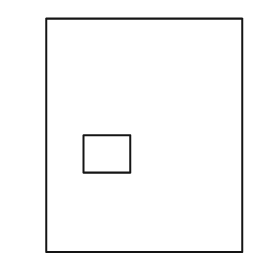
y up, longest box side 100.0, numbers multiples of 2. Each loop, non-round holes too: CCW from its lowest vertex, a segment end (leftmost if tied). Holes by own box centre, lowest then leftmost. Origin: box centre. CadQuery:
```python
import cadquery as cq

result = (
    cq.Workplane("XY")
    .moveTo(-42.0, -50.0)
    .lineTo(42.0, -50.0)
    .lineTo(42.0, 50.0)
    .lineTo(-42.0, 50.0)
    .close()
    .moveTo(-26.0, -16.0)
    .lineTo(-6.0, -16.0)
    .lineTo(-6.0, 0.0)
    .lineTo(-26.0, 0.0)
    .close()
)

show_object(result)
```